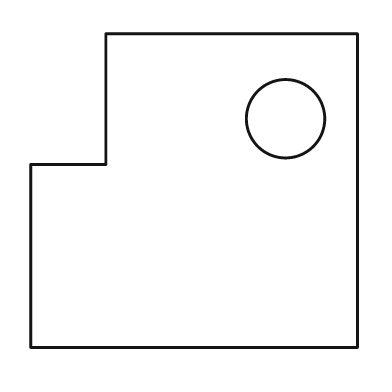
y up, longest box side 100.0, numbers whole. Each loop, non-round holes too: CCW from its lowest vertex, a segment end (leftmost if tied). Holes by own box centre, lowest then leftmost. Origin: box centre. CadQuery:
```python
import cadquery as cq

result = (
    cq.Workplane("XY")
    .moveTo(-50.0, -48.0)
    .lineTo(50.0, -48.0)
    .lineTo(50.0, 48.0)
    .lineTo(-27.0, 48.0)
    .lineTo(-27.0, 8.0)
    .lineTo(-50.0, 8.0)
    .close()
    .moveTo(28.0, 22.0)
    .circle(12.0)
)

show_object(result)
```